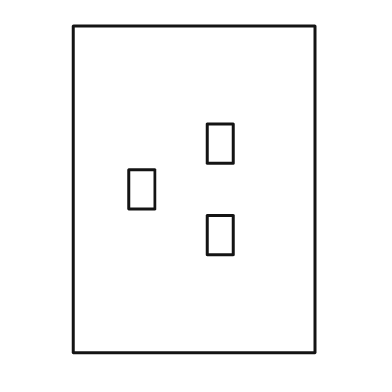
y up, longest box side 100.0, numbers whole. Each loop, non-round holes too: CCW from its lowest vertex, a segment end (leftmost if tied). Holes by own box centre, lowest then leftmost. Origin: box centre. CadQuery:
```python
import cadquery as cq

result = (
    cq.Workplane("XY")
    .moveTo(-37.0, -50.0)
    .lineTo(37.0, -50.0)
    .lineTo(37.0, 50.0)
    .lineTo(-37.0, 50.0)
    .close()
    .moveTo(4.0, -20.0)
    .lineTo(12.0, -20.0)
    .lineTo(12.0, -8.0)
    .lineTo(4.0, -8.0)
    .close()
    .moveTo(-20.0, -6.0)
    .lineTo(-12.0, -6.0)
    .lineTo(-12.0, 6.0)
    .lineTo(-20.0, 6.0)
    .close()
    .moveTo(4.0, 8.0)
    .lineTo(12.0, 8.0)
    .lineTo(12.0, 20.0)
    .lineTo(4.0, 20.0)
    .close()
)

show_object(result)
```